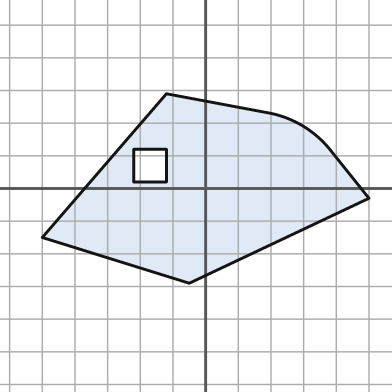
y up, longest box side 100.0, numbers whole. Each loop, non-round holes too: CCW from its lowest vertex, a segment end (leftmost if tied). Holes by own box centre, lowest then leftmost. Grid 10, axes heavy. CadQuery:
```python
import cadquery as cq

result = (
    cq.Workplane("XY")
    .moveTo(-5.0, -29.0)
    .lineTo(50.0, -3.0)
    .lineTo(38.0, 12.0)
    .threePointArc((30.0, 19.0), (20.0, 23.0))
    .lineTo(-12.0, 29.0)
    .lineTo(-50.0, -15.0)
    .close()
    .moveTo(-22.0, 2.0)
    .lineTo(-12.0, 2.0)
    .lineTo(-12.0, 12.0)
    .lineTo(-22.0, 12.0)
    .close()
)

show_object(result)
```